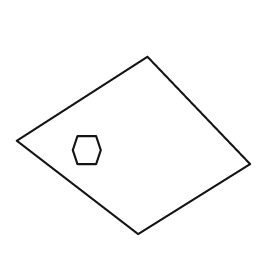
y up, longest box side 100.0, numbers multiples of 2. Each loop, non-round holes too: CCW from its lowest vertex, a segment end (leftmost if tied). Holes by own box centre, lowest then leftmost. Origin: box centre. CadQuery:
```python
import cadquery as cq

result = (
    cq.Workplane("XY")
    .moveTo(2.0, -38.0)
    .lineTo(50.0, -8.0)
    .lineTo(6.0, 38.0)
    .lineTo(-50.0, 2.0)
    .close()
    .moveTo(-24.0, -8.0)
    .lineTo(-16.0, -8.0)
    .lineTo(-14.0, -2.0)
    .lineTo(-16.0, 4.0)
    .lineTo(-24.0, 4.0)
    .lineTo(-26.0, -2.0)
    .close()
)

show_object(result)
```